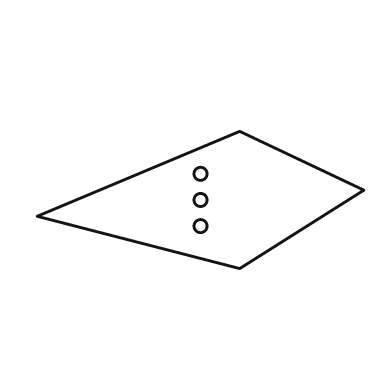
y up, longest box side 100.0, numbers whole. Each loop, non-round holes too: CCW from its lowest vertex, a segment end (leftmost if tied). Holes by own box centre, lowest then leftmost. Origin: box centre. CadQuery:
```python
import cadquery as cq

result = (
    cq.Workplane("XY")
    .moveTo(12.0, -21.0)
    .lineTo(50.0, 3.0)
    .lineTo(12.0, 21.0)
    .lineTo(-50.0, -5.0)
    .close()
    .moveTo(0.0, -8.0)
    .circle(2.0)
    .moveTo(0.0, 0.0)
    .circle(2.0)
    .moveTo(0.0, 8.0)
    .circle(2.0)
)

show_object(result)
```